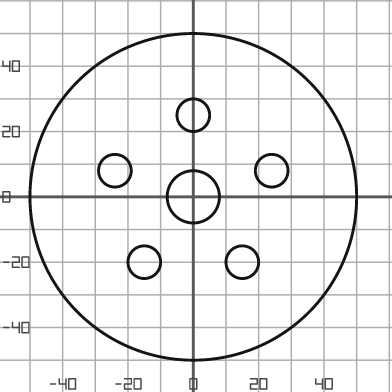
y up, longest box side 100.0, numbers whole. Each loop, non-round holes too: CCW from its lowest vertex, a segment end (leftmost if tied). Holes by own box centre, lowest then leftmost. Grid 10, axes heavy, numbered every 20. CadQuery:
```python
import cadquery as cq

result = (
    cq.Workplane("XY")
    .moveTo(0.0, 0.0)
    .circle(50.0)
    .moveTo(-15.0, -20.0)
    .circle(5.0)
    .moveTo(15.0, -20.0)
    .circle(5.0)
    .moveTo(0.0, 0.0)
    .circle(8.0)
    .moveTo(-24.0, 8.0)
    .circle(5.0)
    .moveTo(24.0, 8.0)
    .circle(5.0)
    .moveTo(0.0, 25.0)
    .circle(5.0)
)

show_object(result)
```